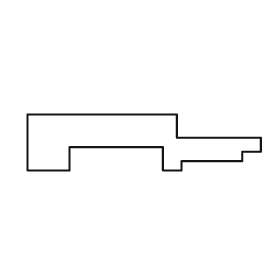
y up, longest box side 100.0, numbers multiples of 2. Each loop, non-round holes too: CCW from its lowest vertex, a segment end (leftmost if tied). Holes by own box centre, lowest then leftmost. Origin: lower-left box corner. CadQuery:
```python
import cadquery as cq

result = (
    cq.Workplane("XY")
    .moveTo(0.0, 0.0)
    .lineTo(18.0, 0.0)
    .lineTo(18.0, 10.0)
    .lineTo(58.0, 10.0)
    .lineTo(58.0, 0.0)
    .lineTo(66.0, 0.0)
    .lineTo(66.0, 4.0)
    .lineTo(92.0, 4.0)
    .lineTo(92.0, 8.0)
    .lineTo(100.0, 8.0)
    .lineTo(100.0, 14.0)
    .lineTo(64.0, 14.0)
    .lineTo(64.0, 24.0)
    .lineTo(0.0, 24.0)
    .close()
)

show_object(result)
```